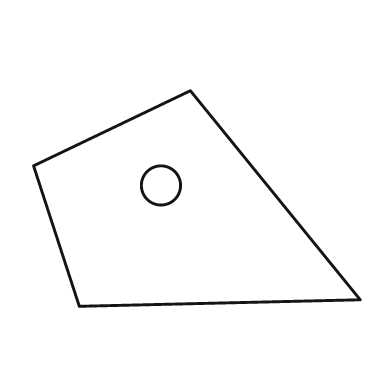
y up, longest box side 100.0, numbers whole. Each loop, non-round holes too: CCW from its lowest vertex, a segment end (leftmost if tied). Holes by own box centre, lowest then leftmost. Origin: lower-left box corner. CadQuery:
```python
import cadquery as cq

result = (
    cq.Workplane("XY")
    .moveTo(14.0, 0.0)
    .lineTo(100.0, 2.0)
    .lineTo(48.0, 66.0)
    .lineTo(0.0, 43.0)
    .close()
    .moveTo(39.0, 37.0)
    .circle(6.0)
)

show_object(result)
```